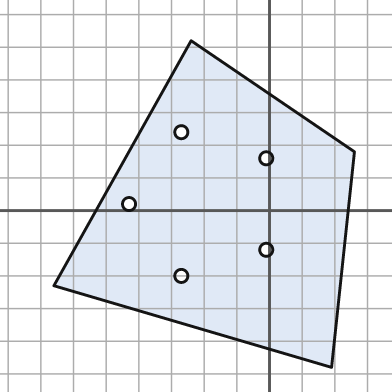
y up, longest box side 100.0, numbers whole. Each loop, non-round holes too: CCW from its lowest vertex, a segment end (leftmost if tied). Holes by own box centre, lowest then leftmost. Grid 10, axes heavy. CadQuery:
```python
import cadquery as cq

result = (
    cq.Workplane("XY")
    .moveTo(19.0, -48.0)
    .lineTo(26.0, 18.0)
    .lineTo(-24.0, 52.0)
    .lineTo(-66.0, -23.0)
    .close()
    .moveTo(-27.0, -20.0)
    .circle(2.0)
    .moveTo(-1.0, -12.0)
    .circle(2.0)
    .moveTo(-43.0, 2.0)
    .circle(2.0)
    .moveTo(-1.0, 16.0)
    .circle(2.0)
    .moveTo(-27.0, 24.0)
    .circle(2.0)
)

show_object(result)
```